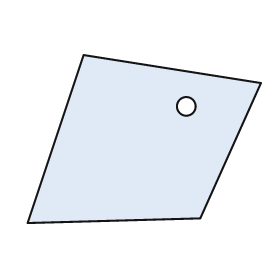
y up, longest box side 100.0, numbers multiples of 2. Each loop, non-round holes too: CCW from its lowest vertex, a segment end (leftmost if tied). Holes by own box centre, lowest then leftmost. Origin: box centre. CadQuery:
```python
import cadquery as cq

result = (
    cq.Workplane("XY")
    .moveTo(-50.0, -36.0)
    .lineTo(24.0, -34.0)
    .lineTo(50.0, 24.0)
    .lineTo(-26.0, 36.0)
    .close()
    .moveTo(18.0, 14.0)
    .circle(4.0)
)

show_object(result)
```